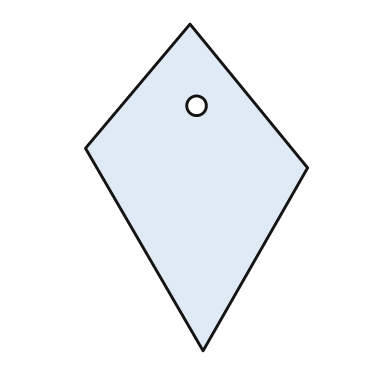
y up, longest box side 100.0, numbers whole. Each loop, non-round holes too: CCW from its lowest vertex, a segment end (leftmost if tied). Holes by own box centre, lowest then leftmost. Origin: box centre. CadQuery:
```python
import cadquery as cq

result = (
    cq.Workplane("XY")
    .moveTo(2.0, -50.0)
    .lineTo(34.0, 6.0)
    .lineTo(-2.0, 50.0)
    .lineTo(-34.0, 12.0)
    .close()
    .moveTo(0.0, 25.0)
    .circle(3.0)
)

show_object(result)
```